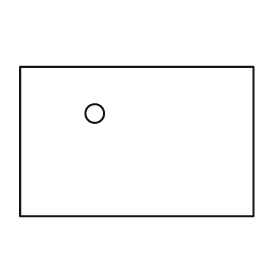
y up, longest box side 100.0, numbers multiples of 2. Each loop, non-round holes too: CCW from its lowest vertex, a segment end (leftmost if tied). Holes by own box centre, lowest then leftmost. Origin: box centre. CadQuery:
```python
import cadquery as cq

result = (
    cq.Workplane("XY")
    .moveTo(-50.0, -32.0)
    .lineTo(50.0, -32.0)
    .lineTo(50.0, 32.0)
    .lineTo(-50.0, 32.0)
    .close()
    .moveTo(-18.0, 12.0)
    .circle(4.0)
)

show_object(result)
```